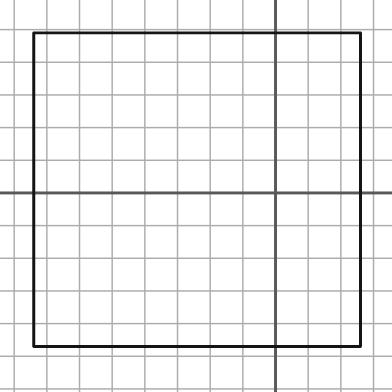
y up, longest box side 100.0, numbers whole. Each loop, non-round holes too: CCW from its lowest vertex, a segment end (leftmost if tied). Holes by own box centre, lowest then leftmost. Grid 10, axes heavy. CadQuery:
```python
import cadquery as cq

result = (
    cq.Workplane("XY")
    .moveTo(-74.0, -47.0)
    .lineTo(26.0, -47.0)
    .lineTo(26.0, 49.0)
    .lineTo(-74.0, 49.0)
    .close()
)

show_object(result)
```